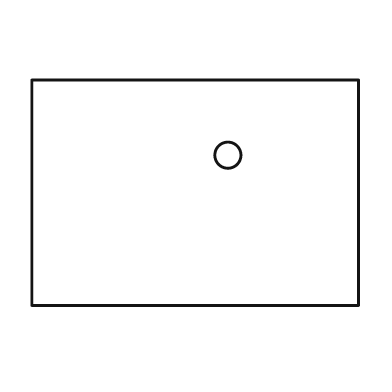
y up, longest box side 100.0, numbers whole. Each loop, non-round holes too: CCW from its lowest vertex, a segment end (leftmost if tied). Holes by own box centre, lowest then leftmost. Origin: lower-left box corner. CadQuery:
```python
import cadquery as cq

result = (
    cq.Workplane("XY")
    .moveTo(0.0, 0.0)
    .lineTo(100.0, 0.0)
    .lineTo(100.0, 69.0)
    .lineTo(0.0, 69.0)
    .close()
    .moveTo(60.0, 46.0)
    .circle(4.0)
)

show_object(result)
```